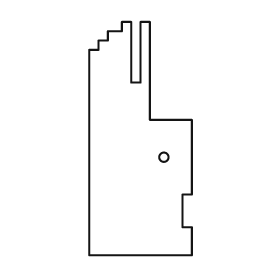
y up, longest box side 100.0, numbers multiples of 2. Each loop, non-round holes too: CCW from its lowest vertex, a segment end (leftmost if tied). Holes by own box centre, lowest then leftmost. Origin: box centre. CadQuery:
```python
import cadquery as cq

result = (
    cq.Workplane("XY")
    .moveTo(-22.0, -50.0)
    .lineTo(22.0, -50.0)
    .lineTo(22.0, -38.0)
    .lineTo(18.0, -38.0)
    .lineTo(18.0, -24.0)
    .lineTo(22.0, -24.0)
    .lineTo(22.0, 8.0)
    .lineTo(4.0, 8.0)
    .lineTo(4.0, 50.0)
    .lineTo(0.0, 50.0)
    .lineTo(0.0, 24.0)
    .lineTo(-4.0, 24.0)
    .lineTo(-4.0, 50.0)
    .lineTo(-8.0, 50.0)
    .lineTo(-8.0, 46.0)
    .lineTo(-14.0, 46.0)
    .lineTo(-14.0, 42.0)
    .lineTo(-18.0, 42.0)
    .lineTo(-18.0, 38.0)
    .lineTo(-22.0, 38.0)
    .close()
    .moveTo(10.0, -8.0)
    .circle(2.0)
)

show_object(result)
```